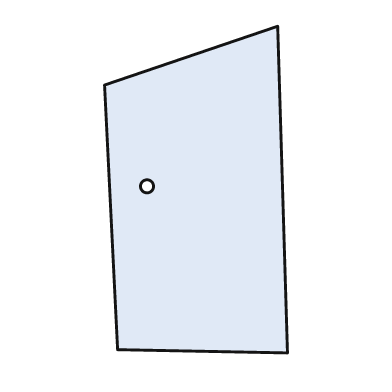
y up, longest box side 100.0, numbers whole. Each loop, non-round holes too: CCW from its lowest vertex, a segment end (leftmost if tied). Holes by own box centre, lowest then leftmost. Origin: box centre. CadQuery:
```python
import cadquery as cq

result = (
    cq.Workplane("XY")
    .moveTo(28.0, -50.0)
    .lineTo(25.0, 50.0)
    .lineTo(-28.0, 32.0)
    .lineTo(-24.0, -49.0)
    .close()
    .moveTo(-15.0, 1.0)
    .circle(2.0)
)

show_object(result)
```